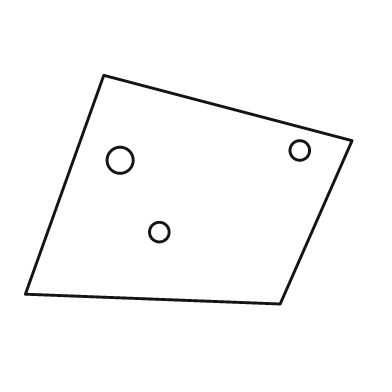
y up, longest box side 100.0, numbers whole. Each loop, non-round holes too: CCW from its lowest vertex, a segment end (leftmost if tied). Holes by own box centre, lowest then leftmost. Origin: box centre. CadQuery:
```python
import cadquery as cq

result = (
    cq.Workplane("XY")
    .moveTo(28.0, -35.0)
    .lineTo(50.0, 15.0)
    .lineTo(-26.0, 35.0)
    .lineTo(-50.0, -32.0)
    .close()
    .moveTo(-9.0, -13.0)
    .circle(3.0)
    .moveTo(-21.0, 9.0)
    .circle(4.0)
    .moveTo(34.0, 12.0)
    .circle(3.0)
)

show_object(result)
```